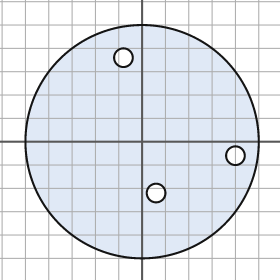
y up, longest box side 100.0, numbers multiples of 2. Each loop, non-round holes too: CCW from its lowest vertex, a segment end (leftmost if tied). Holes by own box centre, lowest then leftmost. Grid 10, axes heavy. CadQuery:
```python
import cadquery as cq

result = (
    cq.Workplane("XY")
    .moveTo(0.0, 0.0)
    .circle(50.0)
    .moveTo(6.0, -22.0)
    .circle(4.0)
    .moveTo(40.0, -6.0)
    .circle(4.0)
    .moveTo(-8.0, 36.0)
    .circle(4.0)
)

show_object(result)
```